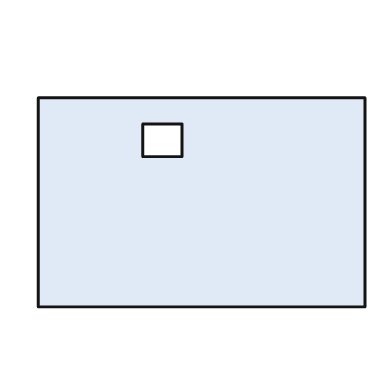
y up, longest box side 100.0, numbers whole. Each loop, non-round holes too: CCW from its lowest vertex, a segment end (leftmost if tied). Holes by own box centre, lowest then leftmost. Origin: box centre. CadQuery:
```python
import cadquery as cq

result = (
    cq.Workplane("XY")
    .moveTo(-50.0, -32.0)
    .lineTo(50.0, -32.0)
    .lineTo(50.0, 32.0)
    .lineTo(-50.0, 32.0)
    .close()
    .moveTo(-18.0, 14.0)
    .lineTo(-6.0, 14.0)
    .lineTo(-6.0, 24.0)
    .lineTo(-18.0, 24.0)
    .close()
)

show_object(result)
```